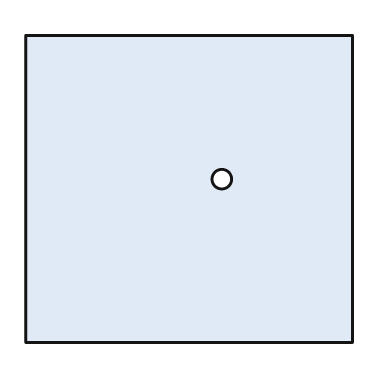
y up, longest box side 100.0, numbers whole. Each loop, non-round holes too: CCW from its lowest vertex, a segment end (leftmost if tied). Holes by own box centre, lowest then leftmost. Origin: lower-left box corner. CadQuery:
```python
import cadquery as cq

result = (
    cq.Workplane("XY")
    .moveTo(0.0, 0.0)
    .lineTo(100.0, 0.0)
    .lineTo(100.0, 94.0)
    .lineTo(0.0, 94.0)
    .close()
    .moveTo(60.0, 50.0)
    .circle(3.0)
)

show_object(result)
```